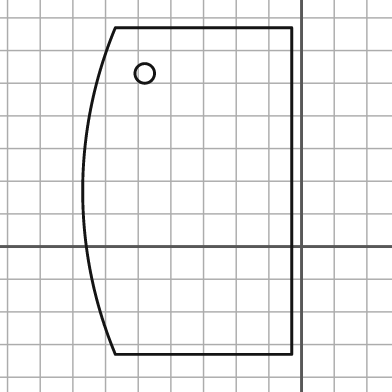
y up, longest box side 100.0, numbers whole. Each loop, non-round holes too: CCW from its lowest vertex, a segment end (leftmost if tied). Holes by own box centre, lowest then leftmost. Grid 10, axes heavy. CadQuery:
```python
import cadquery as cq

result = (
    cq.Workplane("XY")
    .moveTo(-57.0, -33.0)
    .lineTo(-3.0, -33.0)
    .lineTo(-3.0, 67.0)
    .lineTo(-57.0, 67.0)
    .threePointArc((-67.0, 17.0), (-57.0, -33.0))
    .close()
    .moveTo(-48.0, 53.0)
    .circle(3.0)
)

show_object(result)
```